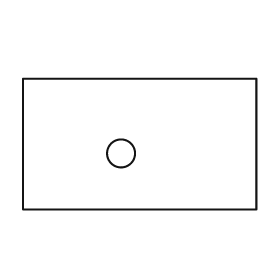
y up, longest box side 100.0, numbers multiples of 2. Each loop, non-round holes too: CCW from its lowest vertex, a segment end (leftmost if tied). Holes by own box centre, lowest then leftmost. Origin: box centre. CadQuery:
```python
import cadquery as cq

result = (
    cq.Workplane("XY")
    .moveTo(-50.0, -28.0)
    .lineTo(50.0, -28.0)
    .lineTo(50.0, 28.0)
    .lineTo(-50.0, 28.0)
    .close()
    .moveTo(-8.0, -4.0)
    .circle(6.0)
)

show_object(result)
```